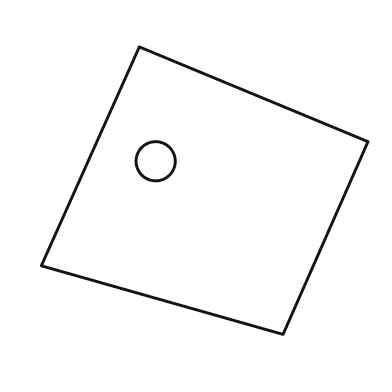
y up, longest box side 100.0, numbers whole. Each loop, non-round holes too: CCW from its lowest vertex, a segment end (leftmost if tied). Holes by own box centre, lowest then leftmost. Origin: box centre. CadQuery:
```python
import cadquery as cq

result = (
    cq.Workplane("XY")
    .moveTo(24.0, -44.0)
    .lineTo(50.0, 15.0)
    .lineTo(-20.0, 44.0)
    .lineTo(-50.0, -23.0)
    .close()
    .moveTo(-15.0, 9.0)
    .circle(6.0)
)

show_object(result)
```